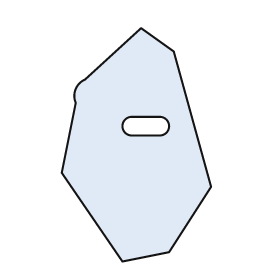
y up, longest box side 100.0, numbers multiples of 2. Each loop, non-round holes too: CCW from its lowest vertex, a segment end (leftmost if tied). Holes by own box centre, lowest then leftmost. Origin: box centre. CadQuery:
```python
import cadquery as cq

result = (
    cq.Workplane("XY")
    .moveTo(-6.0, -50.0)
    .lineTo(14.0, -46.0)
    .lineTo(32.0, -18.0)
    .lineTo(16.0, 40.0)
    .lineTo(2.0, 50.0)
    .lineTo(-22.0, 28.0)
    .threePointArc((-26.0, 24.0), (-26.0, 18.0))
    .lineTo(-32.0, -12.0)
    .close()
    .moveTo(-2.0, 4.0)
    .lineTo(10.0, 4.0)
    .threePointArc((14.0, 8.0), (10.0, 12.0))
    .lineTo(-2.0, 12.0)
    .threePointArc((-6.0, 8.0), (-2.0, 4.0))
    .close()
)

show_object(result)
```